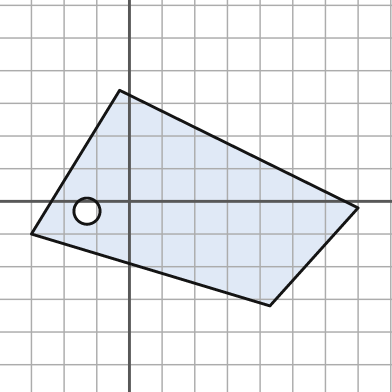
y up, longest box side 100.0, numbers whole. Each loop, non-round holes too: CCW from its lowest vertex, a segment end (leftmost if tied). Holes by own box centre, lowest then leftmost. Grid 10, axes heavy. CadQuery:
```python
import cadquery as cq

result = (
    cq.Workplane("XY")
    .moveTo(43.0, -32.0)
    .lineTo(70.0, -2.0)
    .lineTo(-3.0, 34.0)
    .lineTo(-30.0, -10.0)
    .close()
    .moveTo(-13.0, -3.0)
    .circle(4.0)
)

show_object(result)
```